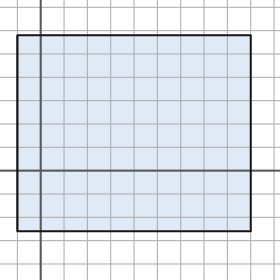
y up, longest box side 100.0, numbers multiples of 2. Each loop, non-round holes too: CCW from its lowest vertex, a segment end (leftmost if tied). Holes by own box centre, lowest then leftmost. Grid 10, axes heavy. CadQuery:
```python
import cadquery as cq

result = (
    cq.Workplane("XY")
    .moveTo(-10.0, -26.0)
    .lineTo(90.0, -26.0)
    .lineTo(90.0, 58.0)
    .lineTo(-10.0, 58.0)
    .close()
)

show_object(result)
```